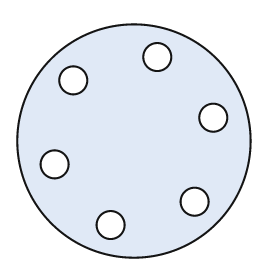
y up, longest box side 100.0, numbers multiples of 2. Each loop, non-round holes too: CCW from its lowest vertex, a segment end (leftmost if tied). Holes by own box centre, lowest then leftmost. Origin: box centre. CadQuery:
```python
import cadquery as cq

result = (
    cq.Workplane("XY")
    .moveTo(0.0, 0.0)
    .circle(50.0)
    .moveTo(-10.0, -36.0)
    .circle(6.0)
    .moveTo(26.0, -26.0)
    .circle(6.0)
    .moveTo(-34.0, -10.0)
    .circle(6.0)
    .moveTo(34.0, 10.0)
    .circle(6.0)
    .moveTo(-26.0, 26.0)
    .circle(6.0)
    .moveTo(10.0, 36.0)
    .circle(6.0)
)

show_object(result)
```